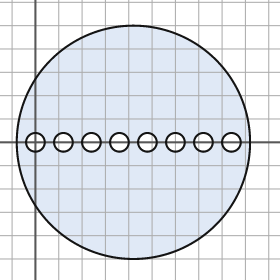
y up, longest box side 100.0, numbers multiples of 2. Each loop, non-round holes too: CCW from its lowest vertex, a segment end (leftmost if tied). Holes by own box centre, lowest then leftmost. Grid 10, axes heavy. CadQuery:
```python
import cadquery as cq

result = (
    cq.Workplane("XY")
    .moveTo(42.0, 0.0)
    .circle(50.0)
    .moveTo(0.0, 0.0)
    .circle(4.0)
    .moveTo(12.0, 0.0)
    .circle(4.0)
    .moveTo(24.0, 0.0)
    .circle(4.0)
    .moveTo(36.0, 0.0)
    .circle(4.0)
    .moveTo(48.0, 0.0)
    .circle(4.0)
    .moveTo(60.0, 0.0)
    .circle(4.0)
    .moveTo(72.0, 0.0)
    .circle(4.0)
    .moveTo(84.0, 0.0)
    .circle(4.0)
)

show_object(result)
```